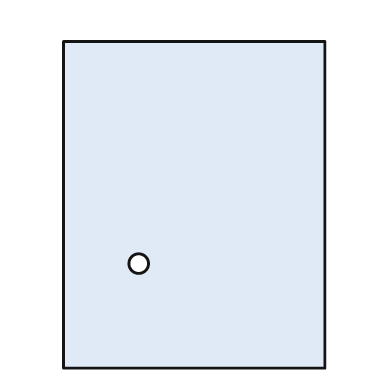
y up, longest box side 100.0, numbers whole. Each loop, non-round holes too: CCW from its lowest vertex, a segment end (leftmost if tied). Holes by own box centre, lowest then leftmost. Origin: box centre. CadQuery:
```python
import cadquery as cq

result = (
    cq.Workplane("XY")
    .moveTo(-40.0, -50.0)
    .lineTo(40.0, -50.0)
    .lineTo(40.0, 50.0)
    .lineTo(-40.0, 50.0)
    .close()
    .moveTo(-17.0, -18.0)
    .circle(3.0)
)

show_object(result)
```